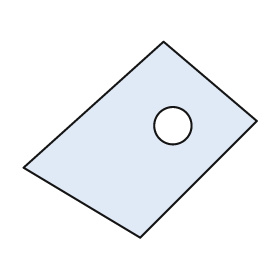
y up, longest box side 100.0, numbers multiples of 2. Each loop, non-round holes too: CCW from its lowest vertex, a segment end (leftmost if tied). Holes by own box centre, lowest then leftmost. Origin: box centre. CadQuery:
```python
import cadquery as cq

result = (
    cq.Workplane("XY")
    .moveTo(0.0, -42.0)
    .lineTo(50.0, 8.0)
    .lineTo(10.0, 42.0)
    .lineTo(-50.0, -12.0)
    .close()
    .moveTo(14.0, 6.0)
    .circle(8.0)
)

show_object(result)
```